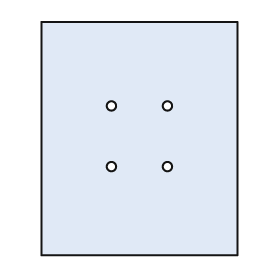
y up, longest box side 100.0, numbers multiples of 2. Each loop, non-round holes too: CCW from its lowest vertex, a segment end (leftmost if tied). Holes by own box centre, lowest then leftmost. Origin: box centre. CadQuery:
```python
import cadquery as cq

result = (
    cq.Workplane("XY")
    .moveTo(-42.0, -50.0)
    .lineTo(42.0, -50.0)
    .lineTo(42.0, 50.0)
    .lineTo(-42.0, 50.0)
    .close()
    .moveTo(-12.0, -12.0)
    .circle(2.0)
    .moveTo(12.0, -12.0)
    .circle(2.0)
    .moveTo(-12.0, 14.0)
    .circle(2.0)
    .moveTo(12.0, 14.0)
    .circle(2.0)
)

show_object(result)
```